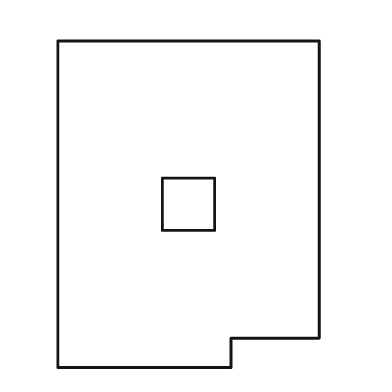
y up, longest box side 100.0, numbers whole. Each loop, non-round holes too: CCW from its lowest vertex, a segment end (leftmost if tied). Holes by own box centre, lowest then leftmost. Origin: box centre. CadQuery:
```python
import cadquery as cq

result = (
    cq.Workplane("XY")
    .moveTo(-40.0, -50.0)
    .lineTo(13.0, -50.0)
    .lineTo(13.0, -41.0)
    .lineTo(40.0, -41.0)
    .lineTo(40.0, 50.0)
    .lineTo(-40.0, 50.0)
    .close()
    .moveTo(-8.0, -8.0)
    .lineTo(8.0, -8.0)
    .lineTo(8.0, 8.0)
    .lineTo(-8.0, 8.0)
    .close()
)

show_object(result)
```